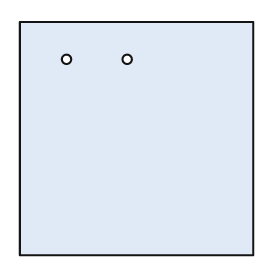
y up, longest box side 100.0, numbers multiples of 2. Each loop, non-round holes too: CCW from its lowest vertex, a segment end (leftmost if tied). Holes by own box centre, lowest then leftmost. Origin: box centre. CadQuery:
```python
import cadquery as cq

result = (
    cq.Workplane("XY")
    .moveTo(-50.0, -50.0)
    .lineTo(50.0, -50.0)
    .lineTo(50.0, 50.0)
    .lineTo(-50.0, 50.0)
    .close()
    .moveTo(-30.0, 34.0)
    .circle(2.0)
    .moveTo(-4.0, 34.0)
    .circle(2.0)
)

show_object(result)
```